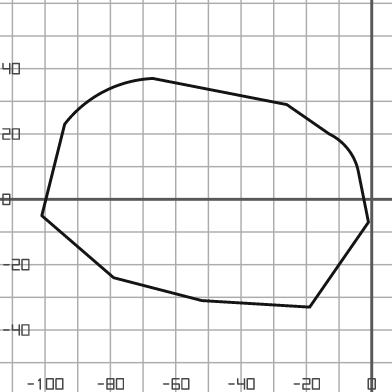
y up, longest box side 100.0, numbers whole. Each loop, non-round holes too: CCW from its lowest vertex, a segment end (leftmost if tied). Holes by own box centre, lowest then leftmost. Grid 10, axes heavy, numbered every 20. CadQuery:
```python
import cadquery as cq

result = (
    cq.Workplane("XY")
    .moveTo(-19.0, -33.0)
    .lineTo(-1.0, -7.0)
    .lineTo(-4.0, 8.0)
    .threePointArc((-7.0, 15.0), (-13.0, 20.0))
    .lineTo(-26.0, 29.0)
    .lineTo(-67.0, 37.0)
    .threePointArc((-82.0, 33.0), (-94.0, 23.0))
    .lineTo(-101.0, -5.0)
    .lineTo(-79.0, -24.0)
    .lineTo(-52.0, -31.0)
    .close()
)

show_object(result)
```